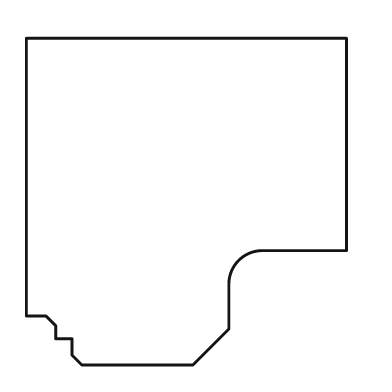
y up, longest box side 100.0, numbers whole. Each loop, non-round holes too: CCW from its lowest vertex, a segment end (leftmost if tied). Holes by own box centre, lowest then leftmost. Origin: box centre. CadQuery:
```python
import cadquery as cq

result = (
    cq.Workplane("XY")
    .moveTo(-32.0, -50.0)
    .lineTo(2.0, -50.0)
    .lineTo(13.0, -39.0)
    .lineTo(13.0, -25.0)
    .threePointArc((16.0, -18.0), (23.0, -15.0))
    .lineTo(49.0, -15.0)
    .lineTo(49.0, 50.0)
    .lineTo(-49.0, 50.0)
    .lineTo(-49.0, -35.0)
    .lineTo(-43.0, -35.0)
    .lineTo(-40.0, -38.0)
    .lineTo(-40.0, -42.0)
    .lineTo(-35.0, -42.0)
    .lineTo(-35.0, -47.0)
    .close()
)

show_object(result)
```